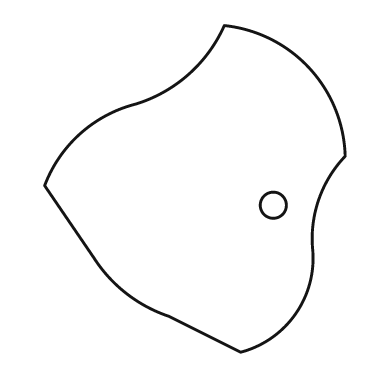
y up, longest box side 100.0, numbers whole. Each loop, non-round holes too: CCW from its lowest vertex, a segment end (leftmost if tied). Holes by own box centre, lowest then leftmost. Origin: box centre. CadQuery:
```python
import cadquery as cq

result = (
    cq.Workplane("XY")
    .moveTo(14.0, -50.0)
    .threePointArc((31.0, -38.0), (36.0, -18.0))
    .threePointArc((38.0, -3.0), (46.0, 10.0))
    .threePointArc((35.0, 37.0), (9.0, 50.0))
    .threePointArc((-2.0, 35.0), (-18.0, 26.0))
    .threePointArc((-35.0, 17.0), (-46.0, 1.0))
    .lineTo(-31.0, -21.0)
    .threePointArc((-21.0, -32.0), (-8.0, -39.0))
    .close()
    .moveTo(24.0, -5.0)
    .circle(4.0)
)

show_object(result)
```